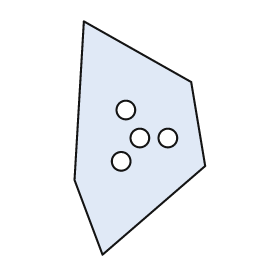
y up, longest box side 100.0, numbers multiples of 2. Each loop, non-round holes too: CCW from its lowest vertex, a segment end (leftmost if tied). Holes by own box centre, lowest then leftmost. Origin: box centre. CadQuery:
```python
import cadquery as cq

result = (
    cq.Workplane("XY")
    .moveTo(-16.0, -50.0)
    .lineTo(28.0, -12.0)
    .lineTo(22.0, 24.0)
    .lineTo(-24.0, 50.0)
    .lineTo(-28.0, -18.0)
    .close()
    .moveTo(-8.0, -10.0)
    .circle(4.0)
    .moveTo(0.0, 0.0)
    .circle(4.0)
    .moveTo(12.0, 0.0)
    .circle(4.0)
    .moveTo(-6.0, 12.0)
    .circle(4.0)
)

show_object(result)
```